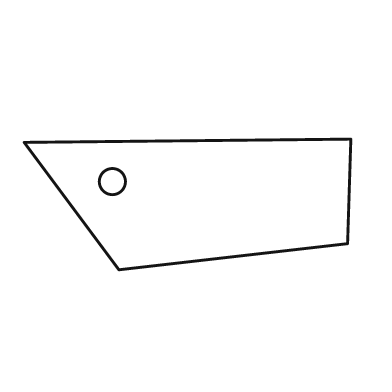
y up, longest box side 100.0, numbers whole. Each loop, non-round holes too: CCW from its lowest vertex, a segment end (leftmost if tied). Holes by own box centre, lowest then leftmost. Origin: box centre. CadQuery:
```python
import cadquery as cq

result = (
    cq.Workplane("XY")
    .moveTo(-21.0, -20.0)
    .lineTo(49.0, -12.0)
    .lineTo(50.0, 20.0)
    .lineTo(-50.0, 19.0)
    .close()
    .moveTo(-23.0, 7.0)
    .circle(4.0)
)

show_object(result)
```